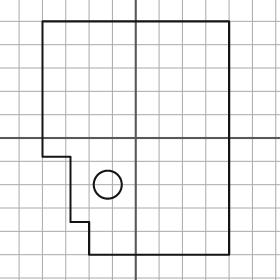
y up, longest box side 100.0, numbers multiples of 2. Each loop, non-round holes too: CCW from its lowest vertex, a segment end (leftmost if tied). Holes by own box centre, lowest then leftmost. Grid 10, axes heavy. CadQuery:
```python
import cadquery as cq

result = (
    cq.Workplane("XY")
    .moveTo(-20.0, -50.0)
    .lineTo(40.0, -50.0)
    .lineTo(40.0, 50.0)
    .lineTo(-40.0, 50.0)
    .lineTo(-40.0, -8.0)
    .lineTo(-28.0, -8.0)
    .lineTo(-28.0, -36.0)
    .lineTo(-20.0, -36.0)
    .close()
    .moveTo(-12.0, -20.0)
    .circle(6.0)
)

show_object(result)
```